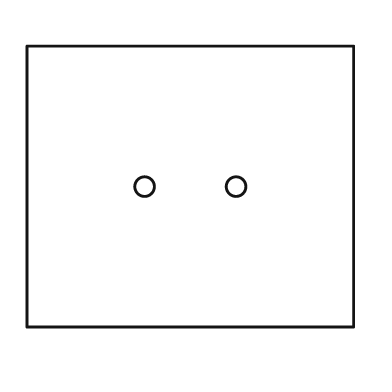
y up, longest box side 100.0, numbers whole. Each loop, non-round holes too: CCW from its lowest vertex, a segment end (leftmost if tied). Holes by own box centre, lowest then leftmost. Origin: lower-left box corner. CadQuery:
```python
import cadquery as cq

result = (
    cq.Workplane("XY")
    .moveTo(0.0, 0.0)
    .lineTo(100.0, 0.0)
    .lineTo(100.0, 86.0)
    .lineTo(0.0, 86.0)
    .close()
    .moveTo(36.0, 43.0)
    .circle(3.0)
    .moveTo(64.0, 43.0)
    .circle(3.0)
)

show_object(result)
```